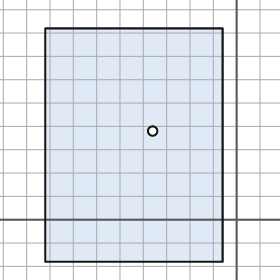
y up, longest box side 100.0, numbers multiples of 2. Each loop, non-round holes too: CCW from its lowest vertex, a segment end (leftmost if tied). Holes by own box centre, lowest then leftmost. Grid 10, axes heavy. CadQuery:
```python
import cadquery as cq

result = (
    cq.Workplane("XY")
    .moveTo(-82.0, -18.0)
    .lineTo(-6.0, -18.0)
    .lineTo(-6.0, 82.0)
    .lineTo(-82.0, 82.0)
    .close()
    .moveTo(-36.0, 38.0)
    .circle(2.0)
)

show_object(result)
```